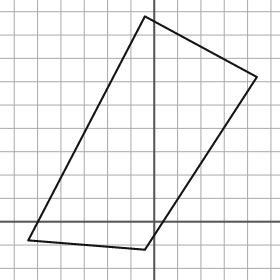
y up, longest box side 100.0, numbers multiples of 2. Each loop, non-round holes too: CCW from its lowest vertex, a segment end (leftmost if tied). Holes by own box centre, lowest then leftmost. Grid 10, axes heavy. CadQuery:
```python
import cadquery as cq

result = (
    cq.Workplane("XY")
    .moveTo(-4.0, -12.0)
    .lineTo(44.0, 62.0)
    .lineTo(-4.0, 88.0)
    .lineTo(-54.0, -8.0)
    .close()
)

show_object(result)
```